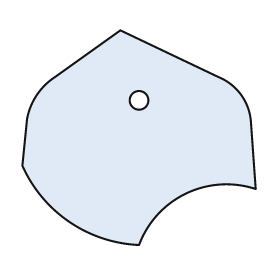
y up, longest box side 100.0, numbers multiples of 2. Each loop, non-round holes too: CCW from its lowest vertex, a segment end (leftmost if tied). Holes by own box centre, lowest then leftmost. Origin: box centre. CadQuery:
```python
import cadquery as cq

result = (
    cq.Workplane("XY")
    .moveTo(0.0, -46.0)
    .threePointArc((20.0, -24.0), (50.0, -22.0))
    .lineTo(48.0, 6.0)
    .threePointArc((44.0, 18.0), (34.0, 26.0))
    .lineTo(-8.0, 46.0)
    .lineTo(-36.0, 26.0)
    .threePointArc((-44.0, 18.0), (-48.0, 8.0))
    .lineTo(-50.0, -12.0)
    .threePointArc((-30.0, -36.0), (0.0, -46.0))
    .close()
    .moveTo(0.0, 16.0)
    .circle(4.0)
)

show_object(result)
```